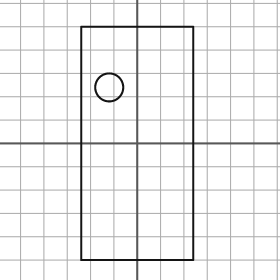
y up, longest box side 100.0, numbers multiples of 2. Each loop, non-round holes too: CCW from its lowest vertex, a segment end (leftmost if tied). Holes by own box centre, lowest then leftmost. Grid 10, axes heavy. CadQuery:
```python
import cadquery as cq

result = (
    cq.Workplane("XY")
    .moveTo(-24.0, -50.0)
    .lineTo(24.0, -50.0)
    .lineTo(24.0, 50.0)
    .lineTo(-24.0, 50.0)
    .close()
    .moveTo(-12.0, 24.0)
    .circle(6.0)
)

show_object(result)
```